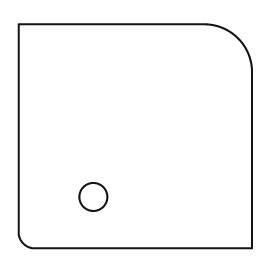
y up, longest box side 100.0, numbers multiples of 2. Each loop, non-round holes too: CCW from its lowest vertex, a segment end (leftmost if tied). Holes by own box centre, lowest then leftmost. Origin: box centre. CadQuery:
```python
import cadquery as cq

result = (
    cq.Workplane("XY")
    .moveTo(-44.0, -48.0)
    .lineTo(50.0, -48.0)
    .lineTo(50.0, 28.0)
    .threePointArc((44.0, 42.0), (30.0, 48.0))
    .lineTo(-50.0, 48.0)
    .lineTo(-50.0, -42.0)
    .threePointArc((-48.0, -46.0), (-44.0, -48.0))
    .close()
    .moveTo(-18.0, -26.0)
    .circle(6.0)
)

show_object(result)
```